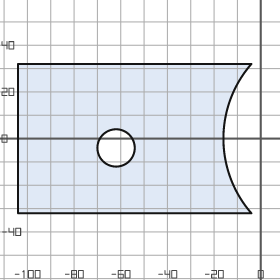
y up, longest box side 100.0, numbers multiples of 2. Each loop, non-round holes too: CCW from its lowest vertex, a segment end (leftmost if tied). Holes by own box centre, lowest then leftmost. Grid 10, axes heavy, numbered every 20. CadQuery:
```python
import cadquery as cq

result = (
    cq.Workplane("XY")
    .moveTo(-104.0, -32.0)
    .lineTo(-4.0, -32.0)
    .threePointArc((-16.0, 0.0), (-4.0, 32.0))
    .lineTo(-104.0, 32.0)
    .close()
    .moveTo(-62.0, -4.0)
    .circle(8.0)
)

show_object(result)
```